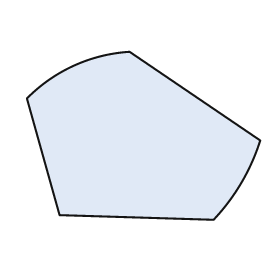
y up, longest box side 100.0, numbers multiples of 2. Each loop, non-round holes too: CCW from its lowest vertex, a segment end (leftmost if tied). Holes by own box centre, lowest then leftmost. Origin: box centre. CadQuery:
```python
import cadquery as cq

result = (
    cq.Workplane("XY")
    .moveTo(30.0, -36.0)
    .threePointArc((42.0, -20.0), (50.0, -2.0))
    .lineTo(-6.0, 36.0)
    .threePointArc((-30.0, 30.0), (-50.0, 16.0))
    .lineTo(-36.0, -34.0)
    .close()
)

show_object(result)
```